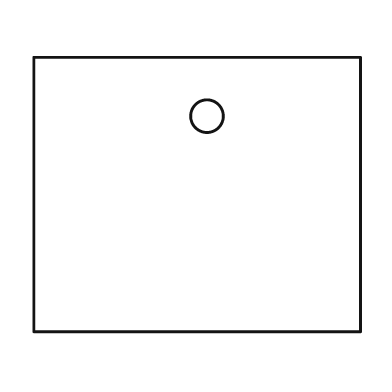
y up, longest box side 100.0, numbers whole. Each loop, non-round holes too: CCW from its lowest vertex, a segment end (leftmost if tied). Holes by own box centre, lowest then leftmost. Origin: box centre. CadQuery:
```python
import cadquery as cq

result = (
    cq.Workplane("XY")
    .moveTo(-50.0, -42.0)
    .lineTo(50.0, -42.0)
    .lineTo(50.0, 42.0)
    .lineTo(-50.0, 42.0)
    .close()
    .moveTo(3.0, 24.0)
    .circle(5.0)
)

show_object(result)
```